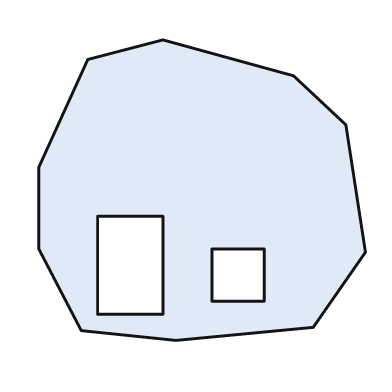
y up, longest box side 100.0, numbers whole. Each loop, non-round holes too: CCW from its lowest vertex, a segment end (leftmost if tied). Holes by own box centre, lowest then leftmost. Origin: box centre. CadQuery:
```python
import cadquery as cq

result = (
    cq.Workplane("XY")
    .moveTo(-8.0, -46.0)
    .lineTo(34.0, -42.0)
    .lineTo(50.0, -19.0)
    .lineTo(44.0, 20.0)
    .lineTo(28.0, 35.0)
    .lineTo(-12.0, 46.0)
    .lineTo(-35.0, 40.0)
    .lineTo(-50.0, 7.0)
    .lineTo(-50.0, -18.0)
    .lineTo(-37.0, -43.0)
    .close()
    .moveTo(3.0, -34.0)
    .lineTo(19.0, -34.0)
    .lineTo(19.0, -18.0)
    .lineTo(3.0, -18.0)
    .close()
    .moveTo(-32.0, -38.0)
    .lineTo(-12.0, -38.0)
    .lineTo(-12.0, -8.0)
    .lineTo(-32.0, -8.0)
    .close()
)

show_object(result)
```